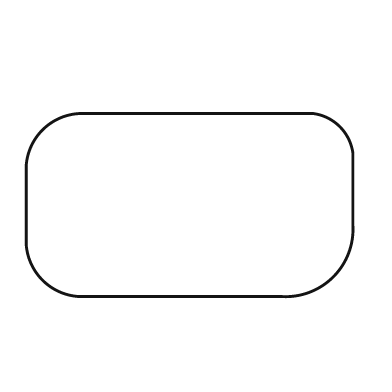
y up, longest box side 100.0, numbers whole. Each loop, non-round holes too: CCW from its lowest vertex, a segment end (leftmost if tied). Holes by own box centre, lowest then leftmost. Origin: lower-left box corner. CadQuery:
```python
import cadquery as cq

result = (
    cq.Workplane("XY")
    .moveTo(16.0, 0.0)
    .lineTo(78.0, 0.0)
    .threePointArc((94.0, 6.0), (100.0, 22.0))
    .lineTo(100.0, 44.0)
    .threePointArc((96.0, 52.0), (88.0, 56.0))
    .lineTo(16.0, 56.0)
    .threePointArc((5.0, 51.0), (0.0, 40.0))
    .lineTo(0.0, 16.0)
    .threePointArc((5.0, 5.0), (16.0, 0.0))
    .close()
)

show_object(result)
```